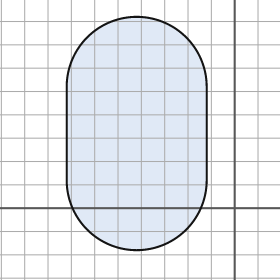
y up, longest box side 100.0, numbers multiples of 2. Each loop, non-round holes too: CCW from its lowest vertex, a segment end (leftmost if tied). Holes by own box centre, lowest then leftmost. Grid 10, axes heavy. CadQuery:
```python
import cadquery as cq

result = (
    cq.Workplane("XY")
    .moveTo(-72.0, 12.0)
    .threePointArc((-42.0, -18.0), (-12.0, 12.0))
    .lineTo(-12.0, 52.0)
    .threePointArc((-42.0, 82.0), (-72.0, 52.0))
    .close()
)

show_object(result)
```